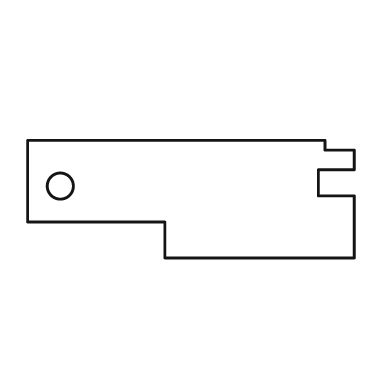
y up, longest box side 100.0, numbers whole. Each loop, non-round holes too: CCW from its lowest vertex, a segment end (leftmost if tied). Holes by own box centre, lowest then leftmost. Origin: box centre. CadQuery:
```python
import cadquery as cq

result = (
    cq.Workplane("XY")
    .moveTo(-8.0, -18.0)
    .lineTo(50.0, -18.0)
    .lineTo(50.0, 1.0)
    .lineTo(39.0, 1.0)
    .lineTo(39.0, 9.0)
    .lineTo(50.0, 9.0)
    .lineTo(50.0, 15.0)
    .lineTo(41.0, 15.0)
    .lineTo(41.0, 18.0)
    .lineTo(-50.0, 18.0)
    .lineTo(-50.0, -7.0)
    .lineTo(-8.0, -7.0)
    .close()
    .moveTo(-40.0, 4.0)
    .circle(4.0)
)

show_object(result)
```